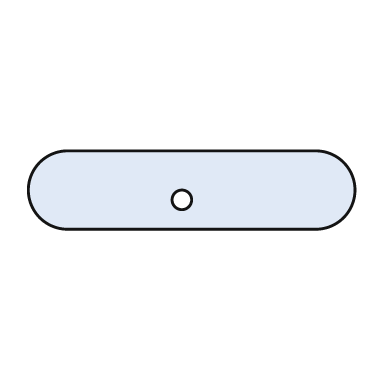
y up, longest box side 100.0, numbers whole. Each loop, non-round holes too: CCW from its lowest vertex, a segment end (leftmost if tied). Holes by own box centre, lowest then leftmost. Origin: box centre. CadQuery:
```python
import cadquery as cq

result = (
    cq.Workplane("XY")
    .moveTo(-38.0, -12.0)
    .lineTo(38.0, -12.0)
    .threePointArc((50.0, 0.0), (38.0, 12.0))
    .lineTo(-38.0, 12.0)
    .threePointArc((-50.0, 0.0), (-38.0, -12.0))
    .close()
    .moveTo(-3.0, -3.0)
    .circle(3.0)
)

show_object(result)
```